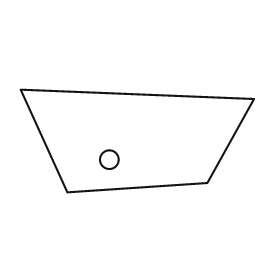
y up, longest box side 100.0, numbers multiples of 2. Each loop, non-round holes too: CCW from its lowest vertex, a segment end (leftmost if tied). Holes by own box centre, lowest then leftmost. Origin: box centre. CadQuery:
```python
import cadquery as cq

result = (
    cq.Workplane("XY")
    .moveTo(-30.0, -22.0)
    .lineTo(30.0, -18.0)
    .lineTo(50.0, 18.0)
    .lineTo(-50.0, 22.0)
    .close()
    .moveTo(-12.0, -8.0)
    .circle(4.0)
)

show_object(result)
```